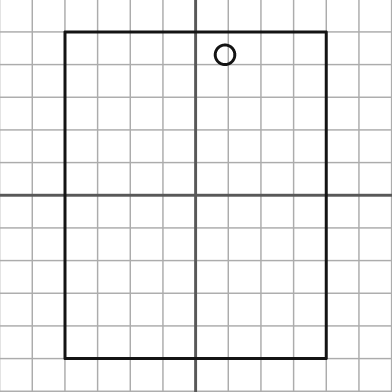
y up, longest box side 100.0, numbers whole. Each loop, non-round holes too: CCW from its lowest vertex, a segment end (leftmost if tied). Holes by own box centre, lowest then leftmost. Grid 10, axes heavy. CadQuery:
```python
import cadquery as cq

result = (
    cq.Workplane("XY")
    .moveTo(-40.0, -50.0)
    .lineTo(40.0, -50.0)
    .lineTo(40.0, 50.0)
    .lineTo(-40.0, 50.0)
    .close()
    .moveTo(9.0, 43.0)
    .circle(3.0)
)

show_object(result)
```